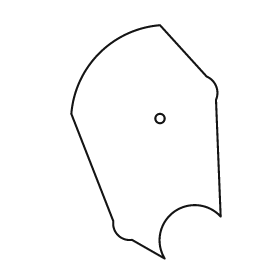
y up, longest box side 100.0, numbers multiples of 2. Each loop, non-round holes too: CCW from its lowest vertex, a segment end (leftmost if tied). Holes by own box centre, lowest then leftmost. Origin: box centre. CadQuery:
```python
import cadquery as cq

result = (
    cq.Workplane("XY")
    .moveTo(8.0, -50.0)
    .threePointArc((12.0, -30.0), (32.0, -32.0))
    .lineTo(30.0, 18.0)
    .threePointArc((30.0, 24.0), (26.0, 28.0))
    .lineTo(6.0, 50.0)
    .threePointArc((-20.0, 38.0), (-32.0, 12.0))
    .lineTo(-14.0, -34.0)
    .threePointArc((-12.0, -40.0), (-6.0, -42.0))
    .close()
    .moveTo(6.0, 10.0)
    .circle(2.0)
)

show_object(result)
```